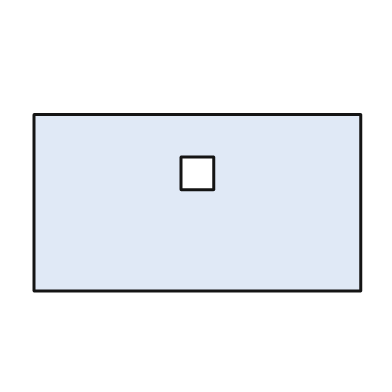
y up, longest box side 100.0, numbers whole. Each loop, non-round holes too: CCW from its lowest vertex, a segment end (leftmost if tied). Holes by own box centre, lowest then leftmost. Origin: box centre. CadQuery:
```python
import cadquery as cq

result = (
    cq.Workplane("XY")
    .moveTo(-50.0, -27.0)
    .lineTo(50.0, -27.0)
    .lineTo(50.0, 27.0)
    .lineTo(-50.0, 27.0)
    .close()
    .moveTo(-5.0, 4.0)
    .lineTo(5.0, 4.0)
    .lineTo(5.0, 14.0)
    .lineTo(-5.0, 14.0)
    .close()
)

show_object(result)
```